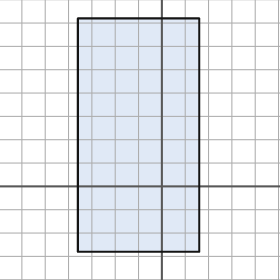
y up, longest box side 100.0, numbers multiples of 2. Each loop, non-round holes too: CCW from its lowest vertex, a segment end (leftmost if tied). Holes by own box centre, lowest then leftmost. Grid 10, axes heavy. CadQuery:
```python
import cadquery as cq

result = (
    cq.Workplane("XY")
    .moveTo(-36.0, -28.0)
    .lineTo(16.0, -28.0)
    .lineTo(16.0, 72.0)
    .lineTo(-36.0, 72.0)
    .close()
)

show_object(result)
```